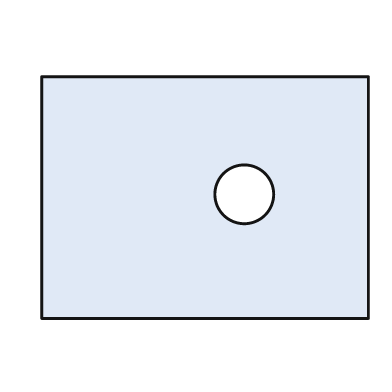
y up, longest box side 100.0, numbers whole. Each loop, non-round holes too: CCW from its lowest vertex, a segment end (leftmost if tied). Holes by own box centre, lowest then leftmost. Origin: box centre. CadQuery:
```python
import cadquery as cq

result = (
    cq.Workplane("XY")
    .moveTo(-50.0, -37.0)
    .lineTo(50.0, -37.0)
    .lineTo(50.0, 37.0)
    .lineTo(-50.0, 37.0)
    .close()
    .moveTo(12.0, 1.0)
    .circle(9.0)
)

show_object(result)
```